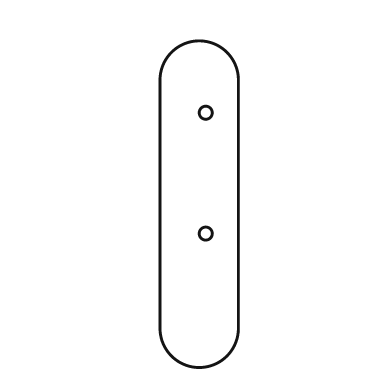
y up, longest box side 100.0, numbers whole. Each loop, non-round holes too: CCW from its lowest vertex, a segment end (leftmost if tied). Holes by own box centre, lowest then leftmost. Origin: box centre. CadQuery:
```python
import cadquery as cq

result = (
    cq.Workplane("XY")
    .moveTo(-12.0, -38.0)
    .threePointArc((0.0, -50.0), (12.0, -38.0))
    .lineTo(12.0, 38.0)
    .threePointArc((0.0, 50.0), (-12.0, 38.0))
    .close()
    .moveTo(2.0, -9.0)
    .circle(2.0)
    .moveTo(2.0, 28.0)
    .circle(2.0)
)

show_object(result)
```